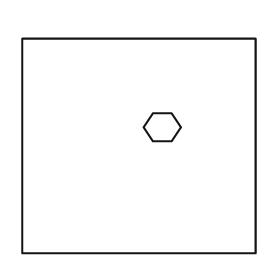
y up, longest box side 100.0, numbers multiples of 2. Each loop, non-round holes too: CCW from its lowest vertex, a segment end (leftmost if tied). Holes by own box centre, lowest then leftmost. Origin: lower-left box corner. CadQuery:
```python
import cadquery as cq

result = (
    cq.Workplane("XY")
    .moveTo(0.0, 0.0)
    .lineTo(100.0, 0.0)
    .lineTo(100.0, 92.0)
    .lineTo(0.0, 92.0)
    .close()
    .moveTo(56.0, 48.0)
    .lineTo(64.0, 48.0)
    .lineTo(68.0, 54.0)
    .lineTo(64.0, 60.0)
    .lineTo(56.0, 60.0)
    .lineTo(52.0, 54.0)
    .close()
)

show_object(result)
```